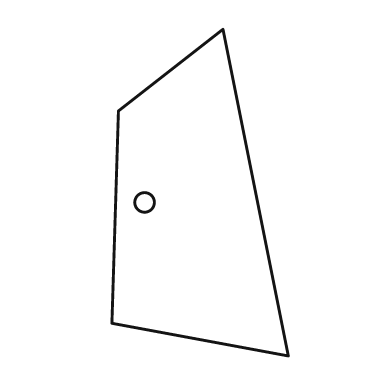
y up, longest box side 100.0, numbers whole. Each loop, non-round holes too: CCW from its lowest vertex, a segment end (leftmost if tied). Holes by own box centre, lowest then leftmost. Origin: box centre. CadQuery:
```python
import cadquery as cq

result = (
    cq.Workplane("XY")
    .moveTo(27.0, -50.0)
    .lineTo(7.0, 50.0)
    .lineTo(-25.0, 25.0)
    .lineTo(-27.0, -40.0)
    .close()
    .moveTo(-17.0, -3.0)
    .circle(3.0)
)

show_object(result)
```